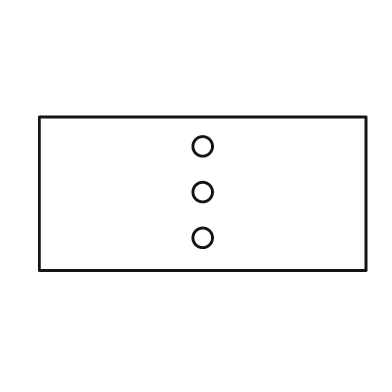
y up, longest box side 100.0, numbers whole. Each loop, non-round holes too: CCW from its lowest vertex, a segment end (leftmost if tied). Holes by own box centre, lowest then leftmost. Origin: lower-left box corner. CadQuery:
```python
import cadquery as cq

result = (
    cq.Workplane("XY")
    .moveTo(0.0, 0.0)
    .lineTo(100.0, 0.0)
    .lineTo(100.0, 47.0)
    .lineTo(0.0, 47.0)
    .close()
    .moveTo(50.0, 10.0)
    .circle(3.0)
    .moveTo(50.0, 24.0)
    .circle(3.0)
    .moveTo(50.0, 38.0)
    .circle(3.0)
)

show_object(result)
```